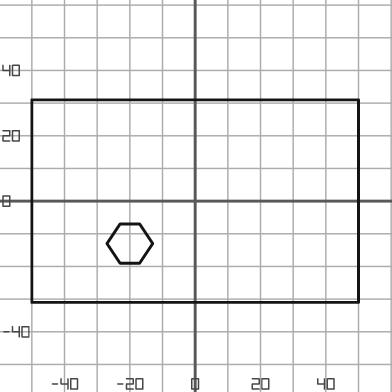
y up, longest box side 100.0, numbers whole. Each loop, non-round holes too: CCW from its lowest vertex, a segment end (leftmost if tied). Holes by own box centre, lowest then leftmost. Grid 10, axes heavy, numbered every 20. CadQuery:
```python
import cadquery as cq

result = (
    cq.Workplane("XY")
    .moveTo(-50.0, -31.0)
    .lineTo(50.0, -31.0)
    .lineTo(50.0, 31.0)
    .lineTo(-50.0, 31.0)
    .close()
    .moveTo(-23.0, -19.0)
    .lineTo(-17.0, -19.0)
    .lineTo(-13.0, -13.0)
    .lineTo(-17.0, -7.0)
    .lineTo(-23.0, -7.0)
    .lineTo(-27.0, -13.0)
    .close()
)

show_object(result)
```